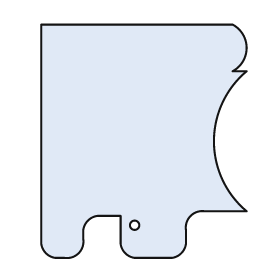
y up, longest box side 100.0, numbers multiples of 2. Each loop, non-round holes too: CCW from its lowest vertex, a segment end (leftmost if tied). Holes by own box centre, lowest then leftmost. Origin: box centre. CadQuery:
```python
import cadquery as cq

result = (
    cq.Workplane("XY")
    .moveTo(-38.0, -50.0)
    .lineTo(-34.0, -50.0)
    .threePointArc((-28.0, -48.0), (-26.0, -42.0))
    .lineTo(-26.0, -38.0)
    .threePointArc((-24.0, -34.0), (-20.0, -32.0))
    .lineTo(-10.0, -32.0)
    .lineTo(-10.0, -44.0)
    .threePointArc((-8.0, -48.0), (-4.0, -50.0))
    .lineTo(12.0, -50.0)
    .threePointArc((16.0, -48.0), (18.0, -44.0))
    .lineTo(18.0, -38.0)
    .threePointArc((20.0, -32.0), (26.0, -30.0))
    .lineTo(44.0, -30.0)
    .threePointArc((30.0, 0.0), (44.0, 30.0))
    .lineTo(38.0, 30.0)
    .threePointArc((44.0, 40.0), (38.0, 50.0))
    .lineTo(-44.0, 50.0)
    .lineTo(-44.0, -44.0)
    .threePointArc((-42.0, -48.0), (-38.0, -50.0))
    .close()
    .moveTo(-4.0, -36.0)
    .circle(2.0)
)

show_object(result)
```